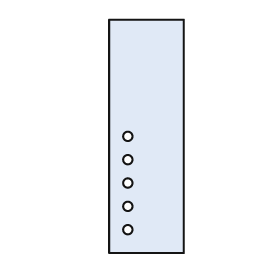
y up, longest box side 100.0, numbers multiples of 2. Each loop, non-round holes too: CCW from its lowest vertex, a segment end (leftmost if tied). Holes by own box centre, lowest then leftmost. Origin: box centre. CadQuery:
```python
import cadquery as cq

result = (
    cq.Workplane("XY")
    .moveTo(-16.0, -50.0)
    .lineTo(16.0, -50.0)
    .lineTo(16.0, 50.0)
    .lineTo(-16.0, 50.0)
    .close()
    .moveTo(-8.0, -40.0)
    .circle(2.0)
    .moveTo(-8.0, -30.0)
    .circle(2.0)
    .moveTo(-8.0, -20.0)
    .circle(2.0)
    .moveTo(-8.0, -10.0)
    .circle(2.0)
    .moveTo(-8.0, 0.0)
    .circle(2.0)
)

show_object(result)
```